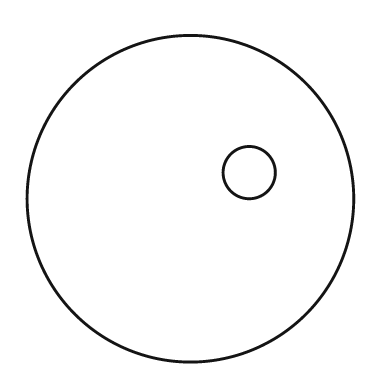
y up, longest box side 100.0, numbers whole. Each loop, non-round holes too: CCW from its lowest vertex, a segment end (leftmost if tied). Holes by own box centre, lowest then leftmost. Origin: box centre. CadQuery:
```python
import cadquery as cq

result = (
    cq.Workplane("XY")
    .moveTo(0.0, 0.0)
    .circle(50.0)
    .moveTo(18.0, 8.0)
    .circle(8.0)
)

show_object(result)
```